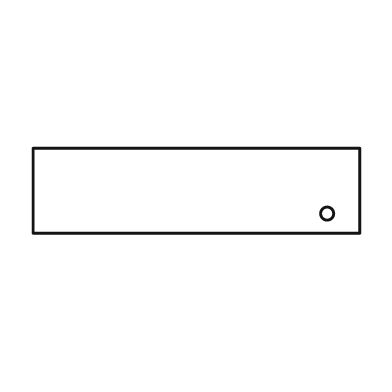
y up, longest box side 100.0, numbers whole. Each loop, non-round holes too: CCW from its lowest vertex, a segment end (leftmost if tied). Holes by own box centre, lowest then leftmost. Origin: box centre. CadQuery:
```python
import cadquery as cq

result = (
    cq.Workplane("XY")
    .moveTo(-50.0, -13.0)
    .lineTo(50.0, -13.0)
    .lineTo(50.0, 13.0)
    .lineTo(-50.0, 13.0)
    .close()
    .moveTo(40.0, -7.0)
    .circle(2.0)
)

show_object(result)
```